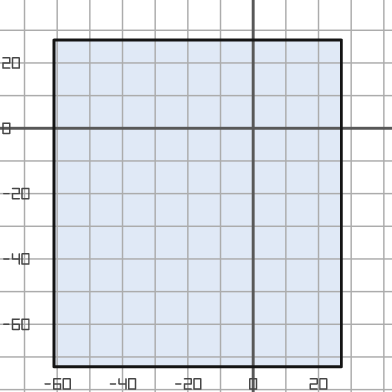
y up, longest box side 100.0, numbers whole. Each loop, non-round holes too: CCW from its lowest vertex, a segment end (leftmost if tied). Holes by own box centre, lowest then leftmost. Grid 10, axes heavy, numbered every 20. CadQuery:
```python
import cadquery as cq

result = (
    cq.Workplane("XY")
    .moveTo(-61.0, -73.0)
    .lineTo(27.0, -73.0)
    .lineTo(27.0, 27.0)
    .lineTo(-61.0, 27.0)
    .close()
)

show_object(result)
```